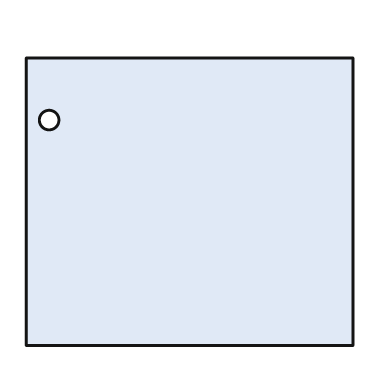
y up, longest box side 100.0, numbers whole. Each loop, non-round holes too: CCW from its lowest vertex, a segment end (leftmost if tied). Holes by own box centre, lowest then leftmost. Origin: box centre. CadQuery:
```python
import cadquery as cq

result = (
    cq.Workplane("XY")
    .moveTo(-50.0, -44.0)
    .lineTo(50.0, -44.0)
    .lineTo(50.0, 44.0)
    .lineTo(-50.0, 44.0)
    .close()
    .moveTo(-43.0, 25.0)
    .circle(3.0)
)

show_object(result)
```